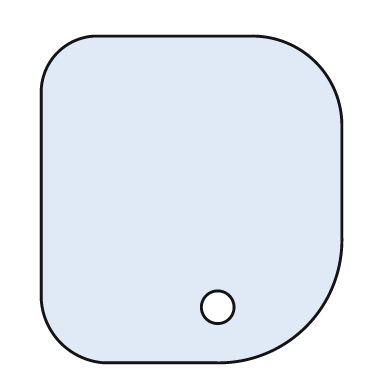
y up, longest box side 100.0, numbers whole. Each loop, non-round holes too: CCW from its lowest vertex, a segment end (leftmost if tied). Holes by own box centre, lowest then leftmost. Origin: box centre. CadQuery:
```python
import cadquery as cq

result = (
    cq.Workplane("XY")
    .moveTo(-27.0, -50.0)
    .lineTo(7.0, -50.0)
    .threePointArc((35.0, -39.0), (46.0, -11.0))
    .lineTo(46.0, 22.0)
    .threePointArc((38.0, 42.0), (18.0, 50.0))
    .lineTo(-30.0, 50.0)
    .threePointArc((-41.0, 45.0), (-46.0, 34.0))
    .lineTo(-46.0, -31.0)
    .threePointArc((-40.0, -44.0), (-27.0, -50.0))
    .close()
    .moveTo(8.0, -33.0)
    .circle(5.0)
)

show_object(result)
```